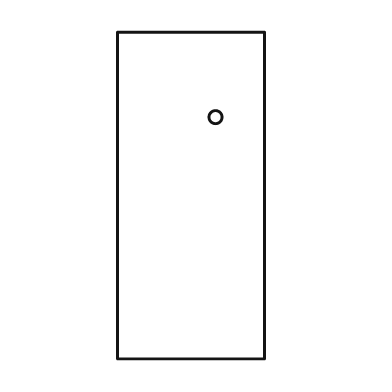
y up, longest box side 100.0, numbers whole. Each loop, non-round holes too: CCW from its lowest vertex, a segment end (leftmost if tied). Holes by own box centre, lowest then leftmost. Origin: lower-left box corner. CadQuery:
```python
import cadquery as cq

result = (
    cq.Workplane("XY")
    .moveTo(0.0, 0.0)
    .lineTo(45.0, 0.0)
    .lineTo(45.0, 100.0)
    .lineTo(0.0, 100.0)
    .close()
    .moveTo(30.0, 74.0)
    .circle(2.0)
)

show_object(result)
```